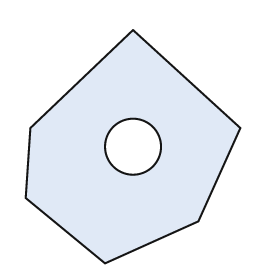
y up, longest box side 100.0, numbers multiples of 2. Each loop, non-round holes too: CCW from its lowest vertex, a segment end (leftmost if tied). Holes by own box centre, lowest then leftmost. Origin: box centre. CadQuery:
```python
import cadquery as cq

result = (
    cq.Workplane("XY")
    .moveTo(-12.0, -50.0)
    .lineTo(28.0, -32.0)
    .lineTo(46.0, 8.0)
    .lineTo(0.0, 50.0)
    .lineTo(-44.0, 8.0)
    .lineTo(-46.0, -22.0)
    .close()
    .moveTo(0.0, 0.0)
    .circle(12.0)
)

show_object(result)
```